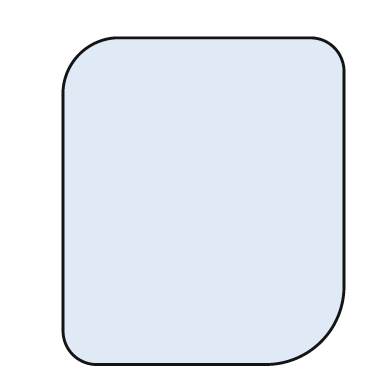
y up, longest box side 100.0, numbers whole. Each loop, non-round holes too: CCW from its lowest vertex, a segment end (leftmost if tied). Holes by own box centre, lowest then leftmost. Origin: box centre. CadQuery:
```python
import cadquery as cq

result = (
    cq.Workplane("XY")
    .moveTo(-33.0, -50.0)
    .lineTo(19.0, -50.0)
    .threePointArc((36.0, -43.0), (43.0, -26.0))
    .lineTo(43.0, 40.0)
    .threePointArc((40.0, 47.0), (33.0, 50.0))
    .lineTo(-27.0, 50.0)
    .threePointArc((-38.0, 45.0), (-43.0, 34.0))
    .lineTo(-43.0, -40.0)
    .threePointArc((-40.0, -47.0), (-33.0, -50.0))
    .close()
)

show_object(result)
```